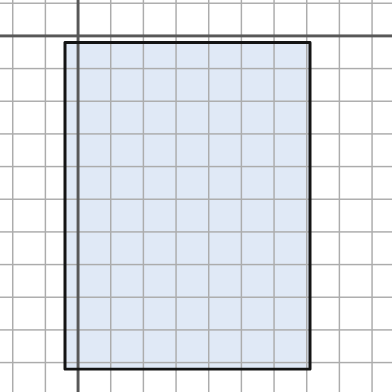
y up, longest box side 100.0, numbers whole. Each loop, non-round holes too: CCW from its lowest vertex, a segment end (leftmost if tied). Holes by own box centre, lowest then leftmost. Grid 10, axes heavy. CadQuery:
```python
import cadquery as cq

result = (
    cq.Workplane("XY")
    .moveTo(-4.0, -102.0)
    .lineTo(71.0, -102.0)
    .lineTo(71.0, -2.0)
    .lineTo(-4.0, -2.0)
    .close()
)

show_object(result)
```